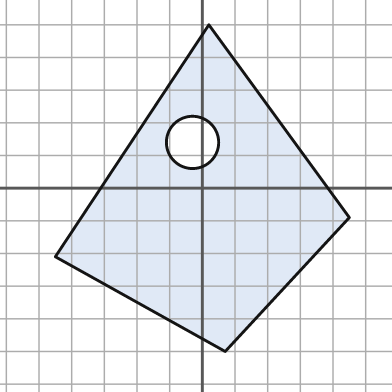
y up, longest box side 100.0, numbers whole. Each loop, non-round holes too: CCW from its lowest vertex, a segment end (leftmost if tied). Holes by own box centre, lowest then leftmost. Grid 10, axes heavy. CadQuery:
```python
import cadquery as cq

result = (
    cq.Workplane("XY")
    .moveTo(7.0, -50.0)
    .lineTo(45.0, -9.0)
    .lineTo(2.0, 50.0)
    .lineTo(-45.0, -21.0)
    .close()
    .moveTo(-3.0, 14.0)
    .circle(8.0)
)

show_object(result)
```